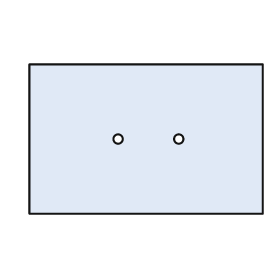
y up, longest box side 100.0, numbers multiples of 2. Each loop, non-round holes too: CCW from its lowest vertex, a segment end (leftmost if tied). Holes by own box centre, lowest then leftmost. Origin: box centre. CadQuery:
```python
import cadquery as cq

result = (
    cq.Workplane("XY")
    .moveTo(-50.0, -32.0)
    .lineTo(50.0, -32.0)
    .lineTo(50.0, 32.0)
    .lineTo(-50.0, 32.0)
    .close()
    .moveTo(-12.0, 0.0)
    .circle(2.0)
    .moveTo(14.0, 0.0)
    .circle(2.0)
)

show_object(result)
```